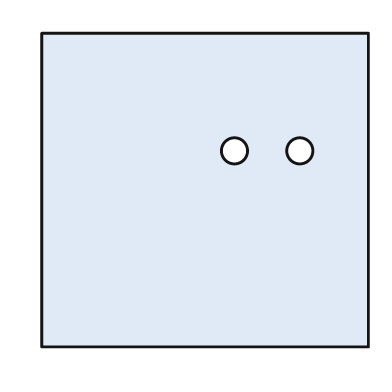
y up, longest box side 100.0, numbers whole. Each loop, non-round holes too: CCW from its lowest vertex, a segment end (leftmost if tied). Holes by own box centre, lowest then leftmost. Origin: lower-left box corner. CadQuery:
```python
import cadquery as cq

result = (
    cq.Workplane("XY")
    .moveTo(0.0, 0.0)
    .lineTo(100.0, 0.0)
    .lineTo(100.0, 96.0)
    .lineTo(0.0, 96.0)
    .close()
    .moveTo(59.0, 60.0)
    .circle(4.0)
    .moveTo(79.0, 60.0)
    .circle(4.0)
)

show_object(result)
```